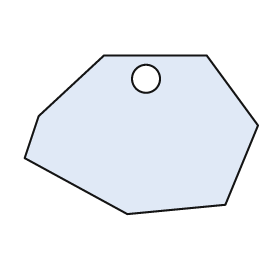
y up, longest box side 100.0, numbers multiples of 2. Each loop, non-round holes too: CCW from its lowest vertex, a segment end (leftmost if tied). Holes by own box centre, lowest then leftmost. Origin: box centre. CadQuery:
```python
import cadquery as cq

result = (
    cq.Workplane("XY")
    .moveTo(-6.0, -34.0)
    .lineTo(36.0, -30.0)
    .lineTo(50.0, 4.0)
    .lineTo(28.0, 34.0)
    .lineTo(-16.0, 34.0)
    .lineTo(-44.0, 8.0)
    .lineTo(-50.0, -10.0)
    .close()
    .moveTo(2.0, 24.0)
    .circle(6.0)
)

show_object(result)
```